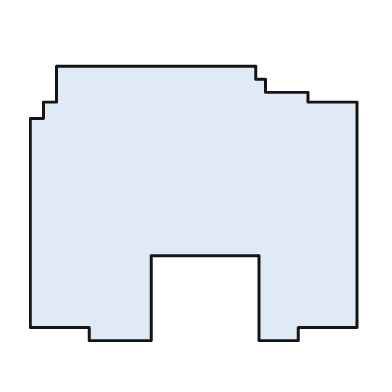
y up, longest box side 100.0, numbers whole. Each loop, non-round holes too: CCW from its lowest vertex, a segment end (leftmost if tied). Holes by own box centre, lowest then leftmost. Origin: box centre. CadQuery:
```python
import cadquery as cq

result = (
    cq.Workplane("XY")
    .moveTo(-32.0, -42.0)
    .lineTo(-13.0, -42.0)
    .lineTo(-13.0, -16.0)
    .lineTo(20.0, -16.0)
    .lineTo(20.0, -42.0)
    .lineTo(32.0, -42.0)
    .lineTo(32.0, -38.0)
    .lineTo(50.0, -38.0)
    .lineTo(50.0, 31.0)
    .lineTo(35.0, 31.0)
    .lineTo(35.0, 34.0)
    .lineTo(22.0, 34.0)
    .lineTo(22.0, 38.0)
    .lineTo(19.0, 38.0)
    .lineTo(19.0, 42.0)
    .lineTo(-42.0, 42.0)
    .lineTo(-42.0, 31.0)
    .lineTo(-46.0, 31.0)
    .lineTo(-46.0, 26.0)
    .lineTo(-50.0, 26.0)
    .lineTo(-50.0, -38.0)
    .lineTo(-32.0, -38.0)
    .close()
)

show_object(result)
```